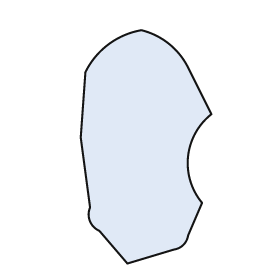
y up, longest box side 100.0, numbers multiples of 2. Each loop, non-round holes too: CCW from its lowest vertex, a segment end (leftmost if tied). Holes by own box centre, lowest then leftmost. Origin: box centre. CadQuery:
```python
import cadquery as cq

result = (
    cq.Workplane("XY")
    .moveTo(-8.0, -50.0)
    .lineTo(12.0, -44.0)
    .threePointArc((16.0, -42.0), (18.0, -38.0))
    .lineTo(24.0, -24.0)
    .threePointArc((18.0, -4.0), (28.0, 14.0))
    .lineTo(18.0, 34.0)
    .threePointArc((10.0, 44.0), (-2.0, 50.0))
    .threePointArc((-16.0, 44.0), (-26.0, 32.0))
    .lineTo(-28.0, 4.0)
    .lineTo(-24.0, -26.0)
    .threePointArc((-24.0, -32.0), (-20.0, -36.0))
    .close()
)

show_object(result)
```